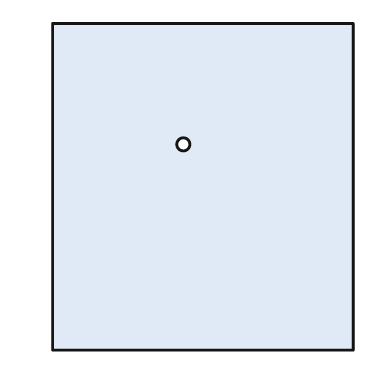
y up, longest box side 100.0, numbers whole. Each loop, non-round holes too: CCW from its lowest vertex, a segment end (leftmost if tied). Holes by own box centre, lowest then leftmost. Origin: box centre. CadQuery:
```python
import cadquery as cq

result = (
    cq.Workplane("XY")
    .moveTo(-46.0, -50.0)
    .lineTo(46.0, -50.0)
    .lineTo(46.0, 50.0)
    .lineTo(-46.0, 50.0)
    .close()
    .moveTo(-6.0, 13.0)
    .circle(2.0)
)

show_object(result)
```